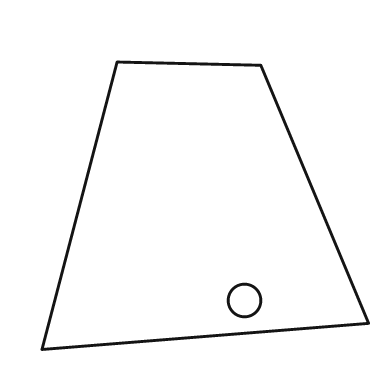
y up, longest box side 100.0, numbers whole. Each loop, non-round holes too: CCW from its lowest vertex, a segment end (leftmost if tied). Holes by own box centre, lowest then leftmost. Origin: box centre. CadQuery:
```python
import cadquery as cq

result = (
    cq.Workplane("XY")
    .moveTo(-50.0, -44.0)
    .lineTo(50.0, -36.0)
    .lineTo(17.0, 43.0)
    .lineTo(-27.0, 44.0)
    .close()
    .moveTo(12.0, -29.0)
    .circle(5.0)
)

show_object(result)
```